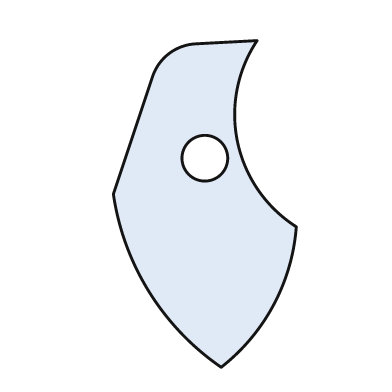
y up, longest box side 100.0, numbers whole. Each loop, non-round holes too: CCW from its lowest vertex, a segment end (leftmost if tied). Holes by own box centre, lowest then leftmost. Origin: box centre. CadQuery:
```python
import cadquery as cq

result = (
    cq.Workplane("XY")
    .moveTo(5.0, -50.0)
    .threePointArc((21.0, -31.0), (28.0, -7.0))
    .threePointArc((10.0, 19.0), (16.0, 50.0))
    .lineTo(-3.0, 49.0)
    .threePointArc((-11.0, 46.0), (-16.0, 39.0))
    .lineTo(-28.0, 3.0)
    .threePointArc((-17.0, -27.0), (5.0, -50.0))
    .close()
    .moveTo(0.0, 14.0)
    .circle(7.0)
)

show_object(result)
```